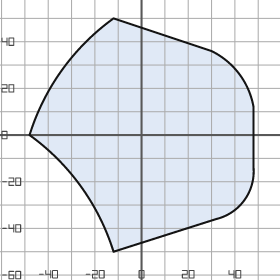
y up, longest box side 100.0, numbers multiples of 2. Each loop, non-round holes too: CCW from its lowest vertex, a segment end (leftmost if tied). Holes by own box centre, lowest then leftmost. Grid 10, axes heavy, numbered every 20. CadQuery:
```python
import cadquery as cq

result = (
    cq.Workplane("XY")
    .moveTo(-12.0, -50.0)
    .lineTo(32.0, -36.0)
    .threePointArc((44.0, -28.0), (48.0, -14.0))
    .lineTo(48.0, 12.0)
    .threePointArc((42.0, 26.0), (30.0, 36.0))
    .lineTo(-12.0, 50.0)
    .threePointArc((-34.0, 28.0), (-48.0, 0.0))
    .threePointArc((-26.0, -22.0), (-12.0, -50.0))
    .close()
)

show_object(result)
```